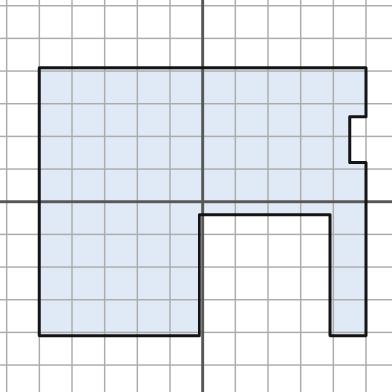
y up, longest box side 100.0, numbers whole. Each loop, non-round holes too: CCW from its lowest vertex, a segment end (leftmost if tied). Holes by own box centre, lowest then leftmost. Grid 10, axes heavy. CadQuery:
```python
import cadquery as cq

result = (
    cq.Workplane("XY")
    .moveTo(-50.0, -41.0)
    .lineTo(-1.0, -41.0)
    .lineTo(-1.0, -4.0)
    .lineTo(39.0, -4.0)
    .lineTo(39.0, -41.0)
    .lineTo(50.0, -41.0)
    .lineTo(50.0, 12.0)
    .lineTo(45.0, 12.0)
    .lineTo(45.0, 26.0)
    .lineTo(50.0, 26.0)
    .lineTo(50.0, 41.0)
    .lineTo(-50.0, 41.0)
    .close()
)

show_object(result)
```